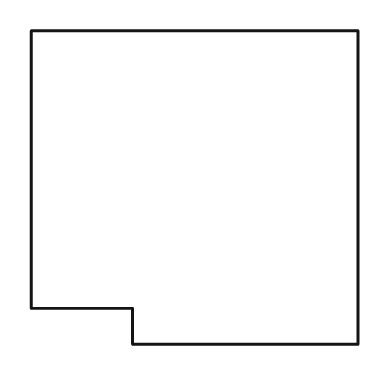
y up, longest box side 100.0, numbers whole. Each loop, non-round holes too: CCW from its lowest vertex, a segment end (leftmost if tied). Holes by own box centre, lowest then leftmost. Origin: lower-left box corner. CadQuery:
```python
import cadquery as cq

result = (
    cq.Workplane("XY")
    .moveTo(31.0, 0.0)
    .lineTo(100.0, 0.0)
    .lineTo(100.0, 96.0)
    .lineTo(0.0, 96.0)
    .lineTo(0.0, 11.0)
    .lineTo(31.0, 11.0)
    .close()
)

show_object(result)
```